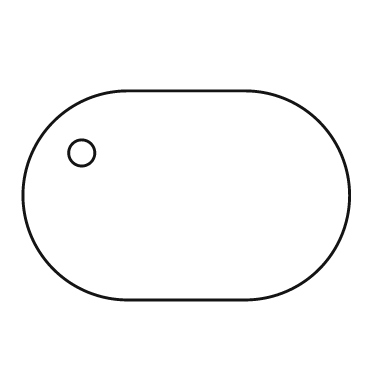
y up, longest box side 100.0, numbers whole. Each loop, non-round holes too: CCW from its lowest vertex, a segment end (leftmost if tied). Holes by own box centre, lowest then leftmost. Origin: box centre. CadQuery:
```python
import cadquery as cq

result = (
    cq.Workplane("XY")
    .moveTo(-18.0, -32.0)
    .lineTo(18.0, -32.0)
    .threePointArc((50.0, 0.0), (18.0, 32.0))
    .lineTo(-18.0, 32.0)
    .threePointArc((-50.0, 0.0), (-18.0, -32.0))
    .close()
    .moveTo(-32.0, 13.0)
    .circle(4.0)
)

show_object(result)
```